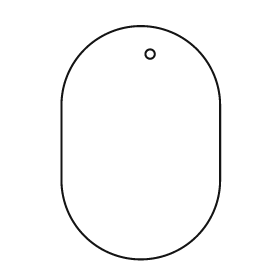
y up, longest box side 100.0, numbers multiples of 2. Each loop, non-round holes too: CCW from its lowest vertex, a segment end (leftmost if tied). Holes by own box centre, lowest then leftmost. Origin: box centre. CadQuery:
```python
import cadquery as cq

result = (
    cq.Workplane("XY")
    .moveTo(-34.0, -16.0)
    .threePointArc((0.0, -50.0), (34.0, -16.0))
    .lineTo(34.0, 16.0)
    .threePointArc((0.0, 50.0), (-34.0, 16.0))
    .close()
    .moveTo(4.0, 38.0)
    .circle(2.0)
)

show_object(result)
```